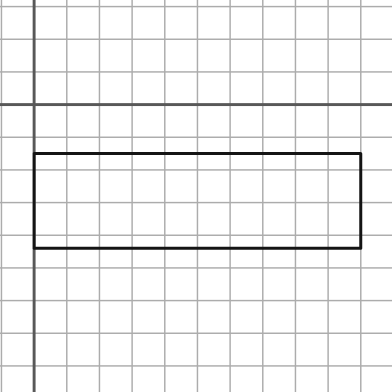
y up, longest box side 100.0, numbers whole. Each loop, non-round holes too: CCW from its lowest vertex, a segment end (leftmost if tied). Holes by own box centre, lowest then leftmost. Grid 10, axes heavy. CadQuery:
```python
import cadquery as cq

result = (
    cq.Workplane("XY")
    .moveTo(0.0, -44.0)
    .lineTo(100.0, -44.0)
    .lineTo(100.0, -15.0)
    .lineTo(0.0, -15.0)
    .close()
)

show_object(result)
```